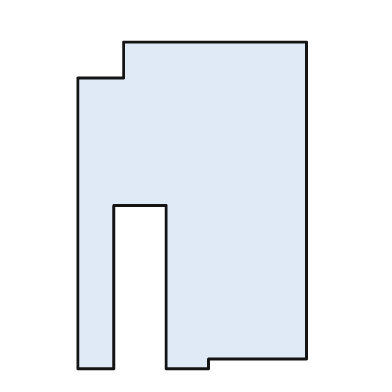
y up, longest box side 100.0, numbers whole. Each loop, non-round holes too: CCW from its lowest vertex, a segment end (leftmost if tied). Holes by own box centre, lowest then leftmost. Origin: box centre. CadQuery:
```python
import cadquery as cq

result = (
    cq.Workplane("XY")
    .moveTo(-35.0, -50.0)
    .lineTo(-24.0, -50.0)
    .lineTo(-24.0, 0.0)
    .lineTo(-8.0, 0.0)
    .lineTo(-8.0, -50.0)
    .lineTo(5.0, -50.0)
    .lineTo(5.0, -47.0)
    .lineTo(35.0, -47.0)
    .lineTo(35.0, 50.0)
    .lineTo(-21.0, 50.0)
    .lineTo(-21.0, 39.0)
    .lineTo(-35.0, 39.0)
    .close()
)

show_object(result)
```